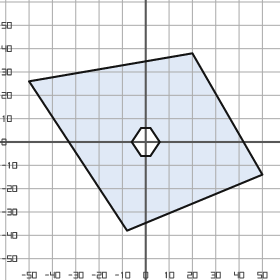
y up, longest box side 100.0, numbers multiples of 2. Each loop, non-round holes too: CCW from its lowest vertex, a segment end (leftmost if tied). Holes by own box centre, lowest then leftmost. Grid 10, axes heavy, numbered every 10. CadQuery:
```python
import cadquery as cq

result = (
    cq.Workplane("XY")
    .moveTo(-8.0, -38.0)
    .lineTo(50.0, -14.0)
    .lineTo(20.0, 38.0)
    .lineTo(-50.0, 26.0)
    .close()
    .moveTo(-2.0, -6.0)
    .lineTo(2.0, -6.0)
    .lineTo(6.0, 0.0)
    .lineTo(2.0, 6.0)
    .lineTo(-2.0, 6.0)
    .lineTo(-6.0, 0.0)
    .close()
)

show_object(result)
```